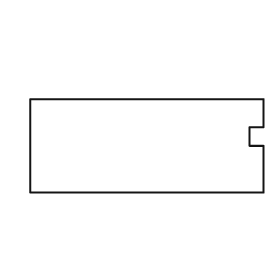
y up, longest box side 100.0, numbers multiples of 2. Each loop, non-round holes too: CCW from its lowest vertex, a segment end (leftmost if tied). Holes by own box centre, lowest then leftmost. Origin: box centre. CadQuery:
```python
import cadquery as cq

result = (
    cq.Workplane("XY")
    .moveTo(-50.0, -20.0)
    .lineTo(50.0, -20.0)
    .lineTo(50.0, 0.0)
    .lineTo(44.0, 0.0)
    .lineTo(44.0, 8.0)
    .lineTo(50.0, 8.0)
    .lineTo(50.0, 20.0)
    .lineTo(-50.0, 20.0)
    .close()
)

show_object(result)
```